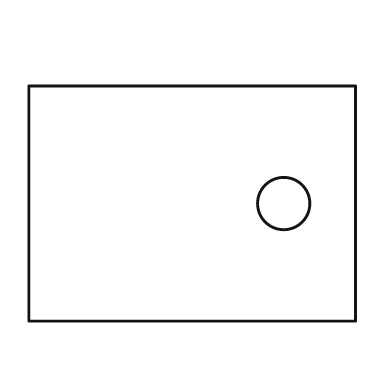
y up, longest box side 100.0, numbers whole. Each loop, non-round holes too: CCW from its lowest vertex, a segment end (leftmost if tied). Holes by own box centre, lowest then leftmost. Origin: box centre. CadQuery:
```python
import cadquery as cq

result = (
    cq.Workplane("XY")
    .moveTo(-50.0, -36.0)
    .lineTo(50.0, -36.0)
    .lineTo(50.0, 36.0)
    .lineTo(-50.0, 36.0)
    .close()
    .moveTo(28.0, 0.0)
    .circle(8.0)
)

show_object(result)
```